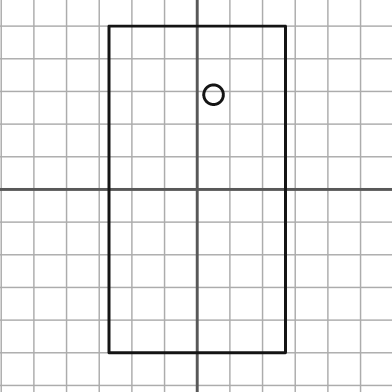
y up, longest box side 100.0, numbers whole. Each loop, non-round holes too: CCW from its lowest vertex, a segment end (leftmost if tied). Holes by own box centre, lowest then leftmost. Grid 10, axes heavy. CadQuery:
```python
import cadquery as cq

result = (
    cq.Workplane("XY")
    .moveTo(-27.0, -50.0)
    .lineTo(27.0, -50.0)
    .lineTo(27.0, 50.0)
    .lineTo(-27.0, 50.0)
    .close()
    .moveTo(5.0, 29.0)
    .circle(3.0)
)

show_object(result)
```